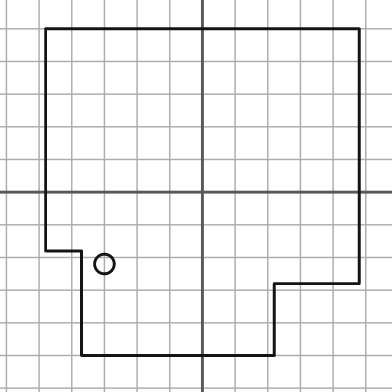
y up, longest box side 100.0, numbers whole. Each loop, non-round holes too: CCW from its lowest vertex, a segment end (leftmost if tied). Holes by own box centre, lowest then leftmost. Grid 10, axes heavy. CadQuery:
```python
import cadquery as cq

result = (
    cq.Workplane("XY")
    .moveTo(-37.0, -50.0)
    .lineTo(22.0, -50.0)
    .lineTo(22.0, -28.0)
    .lineTo(48.0, -28.0)
    .lineTo(48.0, 50.0)
    .lineTo(-48.0, 50.0)
    .lineTo(-48.0, -18.0)
    .lineTo(-37.0, -18.0)
    .close()
    .moveTo(-30.0, -22.0)
    .circle(3.0)
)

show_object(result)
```